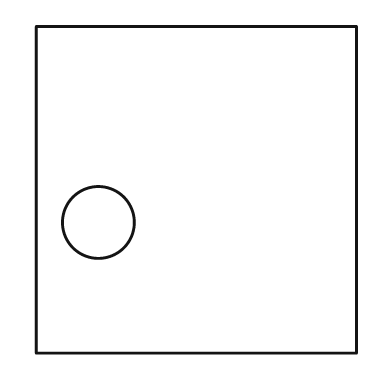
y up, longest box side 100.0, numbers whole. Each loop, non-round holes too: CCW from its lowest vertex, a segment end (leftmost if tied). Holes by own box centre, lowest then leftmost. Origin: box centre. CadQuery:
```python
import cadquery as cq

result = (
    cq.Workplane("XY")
    .moveTo(-49.0, -50.0)
    .lineTo(49.0, -50.0)
    .lineTo(49.0, 50.0)
    .lineTo(-49.0, 50.0)
    .close()
    .moveTo(-30.0, -10.0)
    .circle(11.0)
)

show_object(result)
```